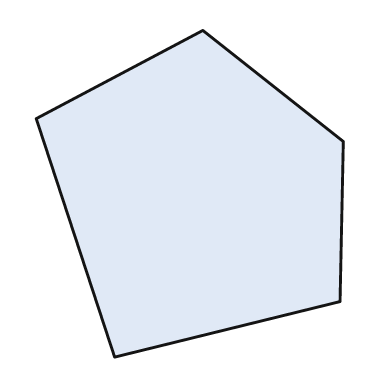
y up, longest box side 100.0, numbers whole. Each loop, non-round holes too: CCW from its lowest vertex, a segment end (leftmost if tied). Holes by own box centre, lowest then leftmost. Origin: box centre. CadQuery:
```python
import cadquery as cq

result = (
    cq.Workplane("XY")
    .moveTo(-23.0, -50.0)
    .lineTo(46.0, -33.0)
    .lineTo(47.0, 16.0)
    .lineTo(4.0, 50.0)
    .lineTo(-47.0, 23.0)
    .close()
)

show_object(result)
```